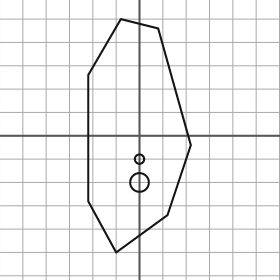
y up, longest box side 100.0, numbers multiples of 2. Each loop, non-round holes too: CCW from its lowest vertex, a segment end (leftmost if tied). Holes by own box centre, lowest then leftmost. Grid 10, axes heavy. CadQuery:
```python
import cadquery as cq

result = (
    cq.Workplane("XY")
    .moveTo(-10.0, -50.0)
    .lineTo(12.0, -34.0)
    .lineTo(22.0, -4.0)
    .lineTo(8.0, 46.0)
    .lineTo(-8.0, 50.0)
    .lineTo(-22.0, 26.0)
    .lineTo(-22.0, -28.0)
    .close()
    .moveTo(0.0, -20.0)
    .circle(4.0)
    .moveTo(0.0, -10.0)
    .circle(2.0)
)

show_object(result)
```